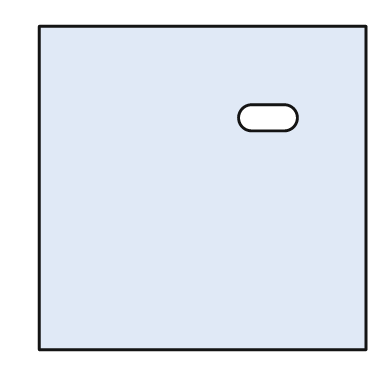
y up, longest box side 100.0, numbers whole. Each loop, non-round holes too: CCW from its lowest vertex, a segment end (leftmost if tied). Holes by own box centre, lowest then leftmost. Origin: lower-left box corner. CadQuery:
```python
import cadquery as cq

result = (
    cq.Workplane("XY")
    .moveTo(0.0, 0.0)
    .lineTo(100.0, 0.0)
    .lineTo(100.0, 99.0)
    .lineTo(0.0, 99.0)
    .close()
    .moveTo(65.0, 67.0)
    .lineTo(75.0, 67.0)
    .threePointArc((79.0, 71.0), (75.0, 75.0))
    .lineTo(65.0, 75.0)
    .threePointArc((61.0, 71.0), (65.0, 67.0))
    .close()
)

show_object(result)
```